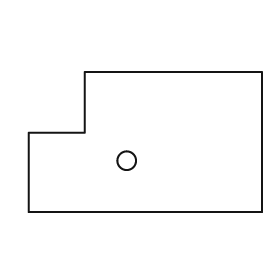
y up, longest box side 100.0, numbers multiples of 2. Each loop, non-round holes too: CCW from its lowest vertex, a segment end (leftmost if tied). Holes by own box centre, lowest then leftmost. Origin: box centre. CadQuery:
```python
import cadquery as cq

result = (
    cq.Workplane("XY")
    .moveTo(-50.0, -30.0)
    .lineTo(50.0, -30.0)
    .lineTo(50.0, 30.0)
    .lineTo(-26.0, 30.0)
    .lineTo(-26.0, 4.0)
    .lineTo(-50.0, 4.0)
    .close()
    .moveTo(-8.0, -8.0)
    .circle(4.0)
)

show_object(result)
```